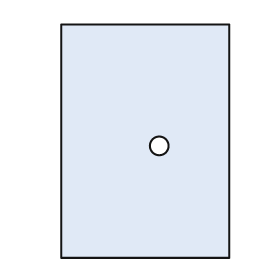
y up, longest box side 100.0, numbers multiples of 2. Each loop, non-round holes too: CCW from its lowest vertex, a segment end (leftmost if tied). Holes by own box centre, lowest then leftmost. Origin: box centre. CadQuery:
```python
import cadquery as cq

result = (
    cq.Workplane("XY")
    .moveTo(-36.0, -50.0)
    .lineTo(36.0, -50.0)
    .lineTo(36.0, 50.0)
    .lineTo(-36.0, 50.0)
    .close()
    .moveTo(6.0, -2.0)
    .circle(4.0)
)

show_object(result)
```